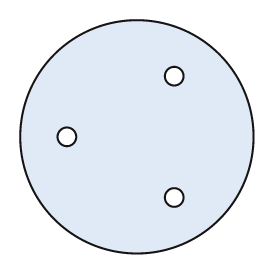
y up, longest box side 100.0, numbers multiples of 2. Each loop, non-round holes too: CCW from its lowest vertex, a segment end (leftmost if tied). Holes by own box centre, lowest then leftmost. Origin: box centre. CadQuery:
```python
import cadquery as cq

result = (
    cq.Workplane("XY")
    .moveTo(0.0, 0.0)
    .circle(50.0)
    .moveTo(16.0, -26.0)
    .circle(4.0)
    .moveTo(-30.0, 0.0)
    .circle(4.0)
    .moveTo(16.0, 26.0)
    .circle(4.0)
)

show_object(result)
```